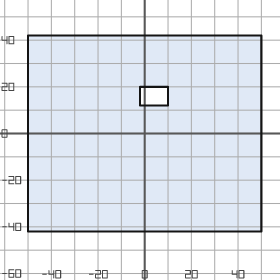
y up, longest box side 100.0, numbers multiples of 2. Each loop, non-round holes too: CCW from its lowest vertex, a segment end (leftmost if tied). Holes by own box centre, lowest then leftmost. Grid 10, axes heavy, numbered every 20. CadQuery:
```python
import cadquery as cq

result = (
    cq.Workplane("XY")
    .moveTo(-50.0, -42.0)
    .lineTo(50.0, -42.0)
    .lineTo(50.0, 42.0)
    .lineTo(-50.0, 42.0)
    .close()
    .moveTo(-2.0, 12.0)
    .lineTo(10.0, 12.0)
    .lineTo(10.0, 20.0)
    .lineTo(-2.0, 20.0)
    .close()
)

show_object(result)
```